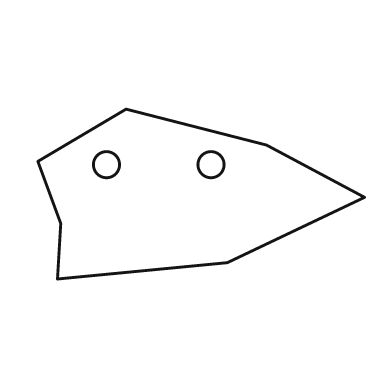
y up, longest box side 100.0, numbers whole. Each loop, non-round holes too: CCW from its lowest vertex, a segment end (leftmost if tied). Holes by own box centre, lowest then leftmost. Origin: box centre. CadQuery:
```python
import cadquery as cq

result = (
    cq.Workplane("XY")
    .moveTo(-44.0, -26.0)
    .lineTo(8.0, -21.0)
    .lineTo(50.0, -1.0)
    .lineTo(20.0, 15.0)
    .lineTo(-23.0, 26.0)
    .lineTo(-50.0, 10.0)
    .lineTo(-43.0, -9.0)
    .close()
    .moveTo(-29.0, 9.0)
    .circle(4.0)
    .moveTo(3.0, 9.0)
    .circle(4.0)
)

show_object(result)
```